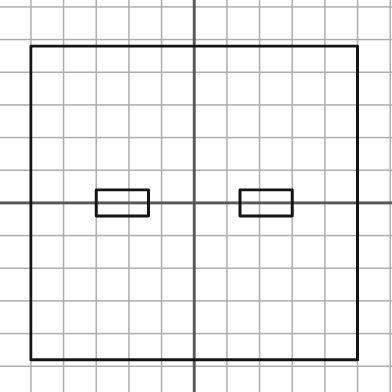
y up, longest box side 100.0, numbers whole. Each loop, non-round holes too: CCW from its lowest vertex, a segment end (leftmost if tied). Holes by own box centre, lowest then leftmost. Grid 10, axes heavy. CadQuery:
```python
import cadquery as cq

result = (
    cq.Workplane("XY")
    .moveTo(-50.0, -48.0)
    .lineTo(50.0, -48.0)
    .lineTo(50.0, 48.0)
    .lineTo(-50.0, 48.0)
    .close()
    .moveTo(-30.0, -4.0)
    .lineTo(-14.0, -4.0)
    .lineTo(-14.0, 4.0)
    .lineTo(-30.0, 4.0)
    .close()
    .moveTo(14.0, -4.0)
    .lineTo(30.0, -4.0)
    .lineTo(30.0, 4.0)
    .lineTo(14.0, 4.0)
    .close()
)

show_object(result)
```